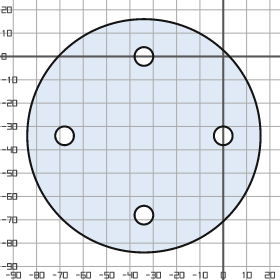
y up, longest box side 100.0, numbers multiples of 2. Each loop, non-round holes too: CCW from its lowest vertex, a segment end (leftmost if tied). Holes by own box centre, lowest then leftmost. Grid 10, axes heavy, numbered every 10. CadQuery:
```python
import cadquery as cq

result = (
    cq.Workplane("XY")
    .moveTo(-34.0, -34.0)
    .circle(50.0)
    .moveTo(-34.0, -68.0)
    .circle(4.0)
    .moveTo(-68.0, -34.0)
    .circle(4.0)
    .moveTo(0.0, -34.0)
    .circle(4.0)
    .moveTo(-34.0, 0.0)
    .circle(4.0)
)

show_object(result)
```